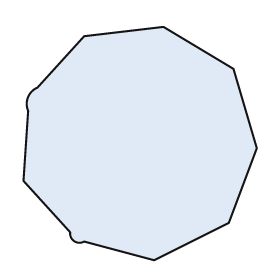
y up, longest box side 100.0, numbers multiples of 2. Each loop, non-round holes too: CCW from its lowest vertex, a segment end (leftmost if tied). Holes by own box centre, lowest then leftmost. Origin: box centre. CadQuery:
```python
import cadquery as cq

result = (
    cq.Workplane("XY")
    .moveTo(6.0, -50.0)
    .lineTo(38.0, -34.0)
    .lineTo(50.0, -2.0)
    .lineTo(40.0, 32.0)
    .lineTo(10.0, 50.0)
    .lineTo(-24.0, 46.0)
    .lineTo(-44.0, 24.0)
    .threePointArc((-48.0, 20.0), (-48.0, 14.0))
    .lineTo(-50.0, -16.0)
    .lineTo(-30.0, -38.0)
    .threePointArc((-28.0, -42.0), (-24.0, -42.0))
    .close()
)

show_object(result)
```